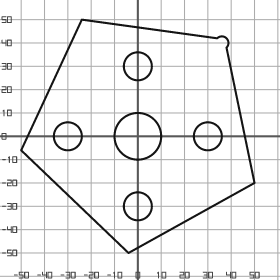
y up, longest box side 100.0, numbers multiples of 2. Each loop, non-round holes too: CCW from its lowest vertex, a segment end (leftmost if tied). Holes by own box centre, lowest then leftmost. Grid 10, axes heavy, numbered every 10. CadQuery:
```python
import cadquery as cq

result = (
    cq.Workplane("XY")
    .moveTo(-4.0, -50.0)
    .lineTo(50.0, -20.0)
    .lineTo(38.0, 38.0)
    .threePointArc((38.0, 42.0), (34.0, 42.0))
    .lineTo(-24.0, 50.0)
    .lineTo(-50.0, -6.0)
    .close()
    .moveTo(0.0, -30.0)
    .circle(6.0)
    .moveTo(-30.0, 0.0)
    .circle(6.0)
    .moveTo(0.0, 0.0)
    .circle(10.0)
    .moveTo(30.0, 0.0)
    .circle(6.0)
    .moveTo(0.0, 30.0)
    .circle(6.0)
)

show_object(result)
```